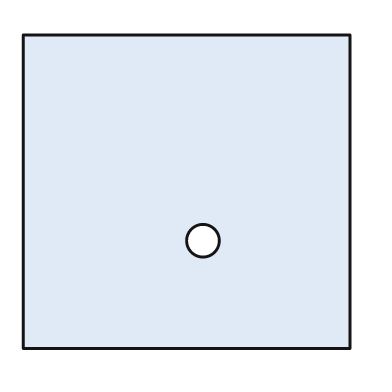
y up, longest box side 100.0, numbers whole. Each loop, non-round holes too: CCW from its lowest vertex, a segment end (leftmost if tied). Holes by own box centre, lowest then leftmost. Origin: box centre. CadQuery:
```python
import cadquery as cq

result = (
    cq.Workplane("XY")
    .moveTo(-50.0, -48.0)
    .lineTo(50.0, -48.0)
    .lineTo(50.0, 48.0)
    .lineTo(-50.0, 48.0)
    .close()
    .moveTo(5.0, -15.0)
    .circle(5.0)
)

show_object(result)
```